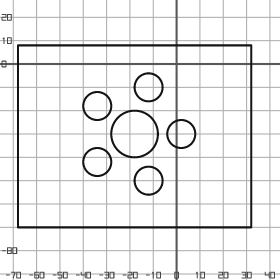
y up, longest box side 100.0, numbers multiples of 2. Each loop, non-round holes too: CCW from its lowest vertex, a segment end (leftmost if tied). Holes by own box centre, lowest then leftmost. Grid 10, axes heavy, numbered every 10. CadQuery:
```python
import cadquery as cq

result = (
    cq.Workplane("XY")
    .moveTo(-68.0, -70.0)
    .lineTo(32.0, -70.0)
    .lineTo(32.0, 8.0)
    .lineTo(-68.0, 8.0)
    .close()
    .moveTo(-12.0, -50.0)
    .circle(6.0)
    .moveTo(-34.0, -42.0)
    .circle(6.0)
    .moveTo(-18.0, -30.0)
    .circle(10.0)
    .moveTo(2.0, -30.0)
    .circle(6.0)
    .moveTo(-34.0, -18.0)
    .circle(6.0)
    .moveTo(-12.0, -10.0)
    .circle(6.0)
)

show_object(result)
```